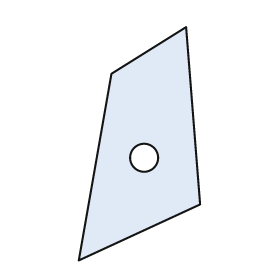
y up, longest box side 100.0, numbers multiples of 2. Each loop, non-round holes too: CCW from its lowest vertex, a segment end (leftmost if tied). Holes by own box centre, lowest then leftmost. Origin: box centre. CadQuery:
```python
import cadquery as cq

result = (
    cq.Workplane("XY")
    .moveTo(-26.0, -50.0)
    .lineTo(26.0, -26.0)
    .lineTo(20.0, 50.0)
    .lineTo(-12.0, 30.0)
    .close()
    .moveTo(2.0, -6.0)
    .circle(6.0)
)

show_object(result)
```